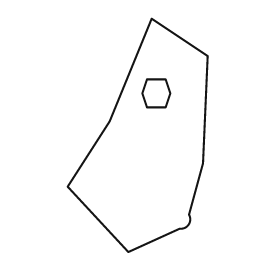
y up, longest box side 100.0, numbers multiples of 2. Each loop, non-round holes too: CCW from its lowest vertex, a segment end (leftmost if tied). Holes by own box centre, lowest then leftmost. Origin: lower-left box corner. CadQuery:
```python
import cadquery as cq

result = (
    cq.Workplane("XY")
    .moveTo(26.0, 0.0)
    .lineTo(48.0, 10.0)
    .threePointArc((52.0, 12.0), (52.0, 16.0))
    .lineTo(58.0, 38.0)
    .lineTo(60.0, 84.0)
    .lineTo(36.0, 100.0)
    .lineTo(18.0, 56.0)
    .lineTo(0.0, 28.0)
    .close()
    .moveTo(34.0, 62.0)
    .lineTo(42.0, 62.0)
    .lineTo(44.0, 68.0)
    .lineTo(42.0, 74.0)
    .lineTo(34.0, 74.0)
    .lineTo(32.0, 68.0)
    .close()
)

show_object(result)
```